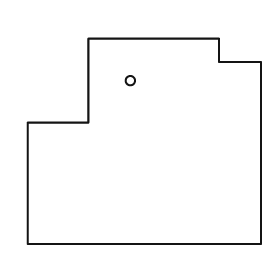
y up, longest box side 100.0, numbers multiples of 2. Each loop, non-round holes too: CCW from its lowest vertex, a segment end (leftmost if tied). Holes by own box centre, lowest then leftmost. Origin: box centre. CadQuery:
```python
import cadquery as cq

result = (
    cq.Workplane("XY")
    .moveTo(-50.0, -44.0)
    .lineTo(50.0, -44.0)
    .lineTo(50.0, 34.0)
    .lineTo(32.0, 34.0)
    .lineTo(32.0, 44.0)
    .lineTo(-24.0, 44.0)
    .lineTo(-24.0, 8.0)
    .lineTo(-50.0, 8.0)
    .close()
    .moveTo(-6.0, 26.0)
    .circle(2.0)
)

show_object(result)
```